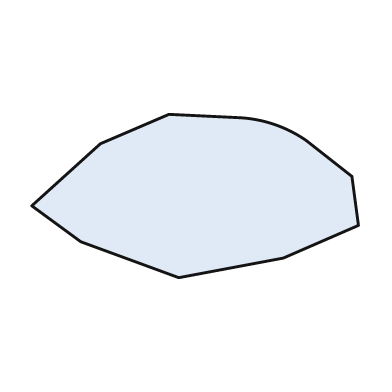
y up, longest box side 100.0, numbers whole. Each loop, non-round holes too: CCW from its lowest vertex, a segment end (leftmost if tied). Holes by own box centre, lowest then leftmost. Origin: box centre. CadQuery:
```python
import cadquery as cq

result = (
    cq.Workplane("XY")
    .moveTo(-5.0, -25.0)
    .lineTo(27.0, -19.0)
    .lineTo(50.0, -9.0)
    .lineTo(48.0, 6.0)
    .lineTo(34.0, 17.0)
    .threePointArc((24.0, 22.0), (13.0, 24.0))
    .lineTo(-8.0, 25.0)
    .lineTo(-29.0, 16.0)
    .lineTo(-50.0, -3.0)
    .lineTo(-35.0, -14.0)
    .close()
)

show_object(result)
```